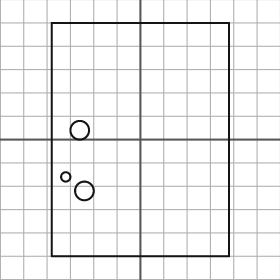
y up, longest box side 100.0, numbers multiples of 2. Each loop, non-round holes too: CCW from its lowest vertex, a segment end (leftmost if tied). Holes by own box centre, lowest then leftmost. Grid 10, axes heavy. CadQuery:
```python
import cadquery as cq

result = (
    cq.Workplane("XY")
    .moveTo(-38.0, -50.0)
    .lineTo(38.0, -50.0)
    .lineTo(38.0, 50.0)
    .lineTo(-38.0, 50.0)
    .close()
    .moveTo(-24.0, -22.0)
    .circle(4.0)
    .moveTo(-32.0, -16.0)
    .circle(2.0)
    .moveTo(-26.0, 4.0)
    .circle(4.0)
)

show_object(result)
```